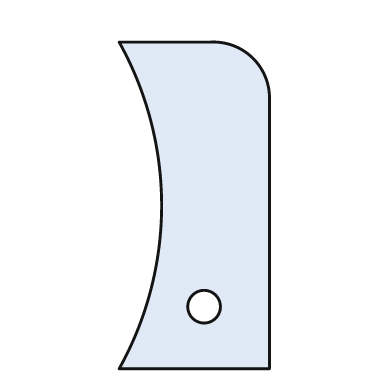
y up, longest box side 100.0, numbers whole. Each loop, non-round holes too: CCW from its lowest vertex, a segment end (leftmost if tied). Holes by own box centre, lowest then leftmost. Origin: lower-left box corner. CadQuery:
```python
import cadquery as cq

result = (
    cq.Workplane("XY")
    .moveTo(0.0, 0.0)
    .lineTo(46.0, 0.0)
    .lineTo(46.0, 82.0)
    .threePointArc((41.0, 95.0), (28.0, 100.0))
    .lineTo(0.0, 100.0)
    .threePointArc((13.0, 50.0), (0.0, 0.0))
    .close()
    .moveTo(26.0, 19.0)
    .circle(5.0)
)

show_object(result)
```